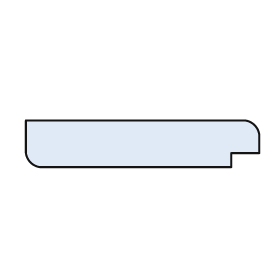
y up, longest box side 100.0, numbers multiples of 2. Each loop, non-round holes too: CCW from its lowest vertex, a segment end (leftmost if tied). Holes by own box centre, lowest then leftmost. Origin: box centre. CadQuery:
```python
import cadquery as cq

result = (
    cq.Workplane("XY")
    .moveTo(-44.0, -10.0)
    .lineTo(38.0, -10.0)
    .lineTo(38.0, -4.0)
    .lineTo(50.0, -4.0)
    .lineTo(50.0, 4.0)
    .threePointArc((48.0, 8.0), (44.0, 10.0))
    .lineTo(-50.0, 10.0)
    .lineTo(-50.0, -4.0)
    .threePointArc((-48.0, -8.0), (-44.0, -10.0))
    .close()
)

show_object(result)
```